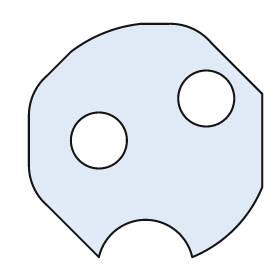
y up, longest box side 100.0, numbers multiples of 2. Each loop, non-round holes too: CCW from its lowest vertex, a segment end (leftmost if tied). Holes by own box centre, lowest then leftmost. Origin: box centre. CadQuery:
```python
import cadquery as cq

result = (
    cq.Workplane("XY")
    .moveTo(-20.0, -50.0)
    .threePointArc((0.0, -34.0), (20.0, -50.0))
    .threePointArc((38.0, -38.0), (50.0, -20.0))
    .lineTo(50.0, 20.0)
    .lineTo(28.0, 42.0)
    .threePointArc((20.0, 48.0), (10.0, 50.0))
    .lineTo(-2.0, 50.0)
    .threePointArc((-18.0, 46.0), (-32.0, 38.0))
    .lineTo(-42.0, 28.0)
    .threePointArc((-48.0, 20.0), (-50.0, 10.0))
    .lineTo(-50.0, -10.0)
    .threePointArc((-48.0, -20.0), (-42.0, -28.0))
    .close()
    .moveTo(-20.0, 0.0)
    .circle(12.0)
    .moveTo(26.0, 18.0)
    .circle(12.0)
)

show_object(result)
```